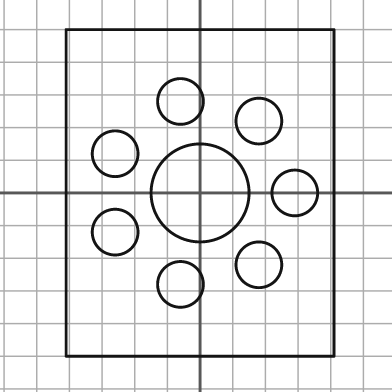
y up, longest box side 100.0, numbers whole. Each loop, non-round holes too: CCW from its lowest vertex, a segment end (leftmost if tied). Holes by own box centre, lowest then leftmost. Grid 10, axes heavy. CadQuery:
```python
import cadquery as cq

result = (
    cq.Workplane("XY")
    .moveTo(-41.0, -50.0)
    .lineTo(41.0, -50.0)
    .lineTo(41.0, 50.0)
    .lineTo(-41.0, 50.0)
    .close()
    .moveTo(-6.0, -28.0)
    .circle(7.0)
    .moveTo(18.0, -22.0)
    .circle(7.0)
    .moveTo(-26.0, -12.0)
    .circle(7.0)
    .moveTo(0.0, 0.0)
    .circle(15.0)
    .moveTo(29.0, 0.0)
    .circle(7.0)
    .moveTo(-26.0, 12.0)
    .circle(7.0)
    .moveTo(18.0, 22.0)
    .circle(7.0)
    .moveTo(-6.0, 28.0)
    .circle(7.0)
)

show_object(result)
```